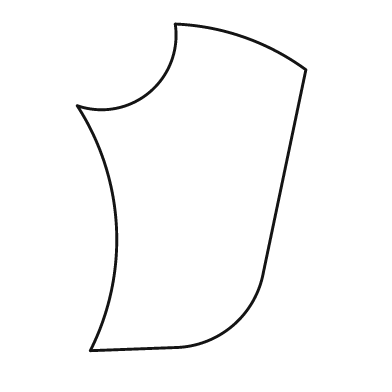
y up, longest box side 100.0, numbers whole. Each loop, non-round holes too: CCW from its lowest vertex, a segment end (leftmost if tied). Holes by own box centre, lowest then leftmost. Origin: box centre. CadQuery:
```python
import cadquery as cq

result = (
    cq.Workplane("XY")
    .moveTo(-31.0, -50.0)
    .lineTo(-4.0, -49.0)
    .threePointArc((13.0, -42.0), (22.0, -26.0))
    .lineTo(35.0, 36.0)
    .threePointArc((16.0, 46.0), (-5.0, 50.0))
    .threePointArc((-13.0, 29.0), (-35.0, 25.0))
    .threePointArc((-23.0, -12.0), (-31.0, -50.0))
    .close()
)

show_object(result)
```